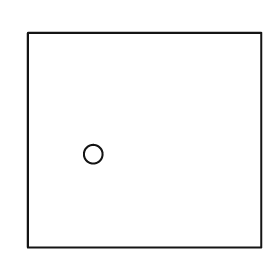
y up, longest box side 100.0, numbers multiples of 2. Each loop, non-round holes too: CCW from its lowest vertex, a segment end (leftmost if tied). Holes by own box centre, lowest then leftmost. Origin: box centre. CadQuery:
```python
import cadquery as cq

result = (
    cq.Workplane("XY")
    .moveTo(-50.0, -46.0)
    .lineTo(50.0, -46.0)
    .lineTo(50.0, 46.0)
    .lineTo(-50.0, 46.0)
    .close()
    .moveTo(-22.0, -6.0)
    .circle(4.0)
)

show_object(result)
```